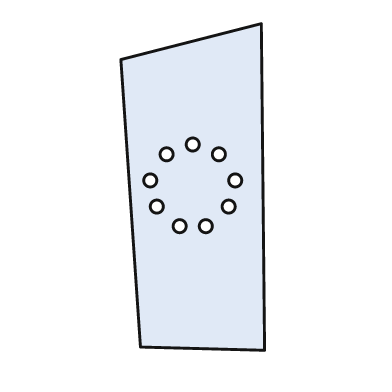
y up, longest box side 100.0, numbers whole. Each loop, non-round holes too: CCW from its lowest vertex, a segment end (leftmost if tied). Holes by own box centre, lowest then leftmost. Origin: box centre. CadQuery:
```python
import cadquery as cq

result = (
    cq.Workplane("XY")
    .moveTo(22.0, -50.0)
    .lineTo(21.0, 50.0)
    .lineTo(-22.0, 39.0)
    .lineTo(-16.0, -49.0)
    .close()
    .moveTo(-4.0, -12.0)
    .circle(2.0)
    .moveTo(4.0, -12.0)
    .circle(2.0)
    .moveTo(-11.0, -6.0)
    .circle(2.0)
    .moveTo(11.0, -6.0)
    .circle(2.0)
    .moveTo(-13.0, 2.0)
    .circle(2.0)
    .moveTo(13.0, 2.0)
    .circle(2.0)
    .moveTo(-8.0, 10.0)
    .circle(2.0)
    .moveTo(8.0, 10.0)
    .circle(2.0)
    .moveTo(0.0, 13.0)
    .circle(2.0)
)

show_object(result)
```